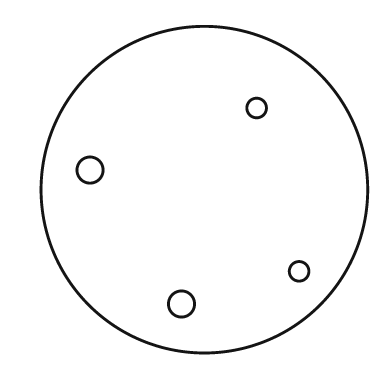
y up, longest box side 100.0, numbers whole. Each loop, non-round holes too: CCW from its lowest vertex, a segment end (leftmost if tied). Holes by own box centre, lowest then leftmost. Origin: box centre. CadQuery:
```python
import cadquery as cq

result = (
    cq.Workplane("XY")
    .moveTo(0.0, 0.0)
    .circle(50.0)
    .moveTo(-7.0, -35.0)
    .circle(4.0)
    .moveTo(29.0, -25.0)
    .circle(3.0)
    .moveTo(-35.0, 6.0)
    .circle(4.0)
    .moveTo(16.0, 25.0)
    .circle(3.0)
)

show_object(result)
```